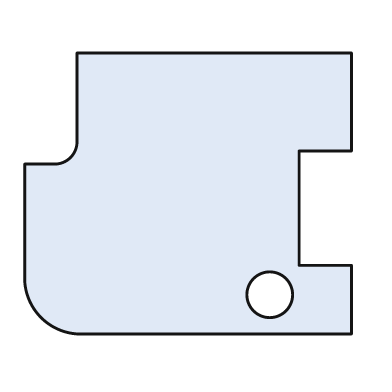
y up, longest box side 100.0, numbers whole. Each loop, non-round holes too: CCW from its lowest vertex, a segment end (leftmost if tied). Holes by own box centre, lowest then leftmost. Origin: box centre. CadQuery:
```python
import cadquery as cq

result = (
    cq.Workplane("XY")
    .moveTo(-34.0, -43.0)
    .lineTo(50.0, -43.0)
    .lineTo(50.0, -22.0)
    .lineTo(34.0, -22.0)
    .lineTo(34.0, 13.0)
    .lineTo(50.0, 13.0)
    .lineTo(50.0, 43.0)
    .lineTo(-34.0, 43.0)
    .lineTo(-34.0, 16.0)
    .threePointArc((-36.0, 11.0), (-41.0, 9.0))
    .lineTo(-50.0, 9.0)
    .lineTo(-50.0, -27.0)
    .threePointArc((-45.0, -38.0), (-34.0, -43.0))
    .close()
    .moveTo(25.0, -31.0)
    .circle(7.0)
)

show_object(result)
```